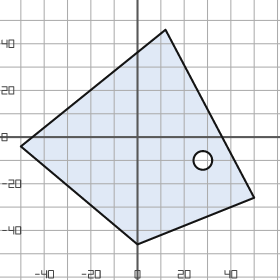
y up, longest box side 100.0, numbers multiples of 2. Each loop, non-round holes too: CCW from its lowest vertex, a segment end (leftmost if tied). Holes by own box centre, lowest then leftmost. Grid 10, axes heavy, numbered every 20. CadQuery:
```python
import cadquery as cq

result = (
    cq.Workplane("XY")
    .moveTo(0.0, -46.0)
    .lineTo(50.0, -26.0)
    .lineTo(12.0, 46.0)
    .lineTo(-50.0, -4.0)
    .close()
    .moveTo(28.0, -10.0)
    .circle(4.0)
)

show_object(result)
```